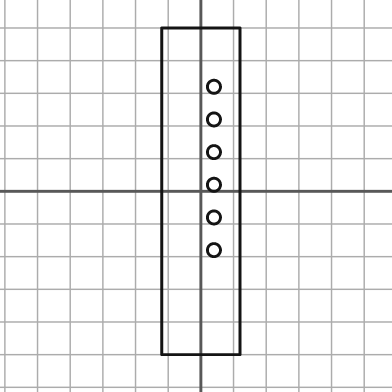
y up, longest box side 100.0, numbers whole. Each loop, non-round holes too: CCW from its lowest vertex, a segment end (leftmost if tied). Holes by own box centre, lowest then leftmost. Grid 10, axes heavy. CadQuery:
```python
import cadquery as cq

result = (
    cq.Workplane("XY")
    .moveTo(-12.0, -50.0)
    .lineTo(12.0, -50.0)
    .lineTo(12.0, 50.0)
    .lineTo(-12.0, 50.0)
    .close()
    .moveTo(4.0, -18.0)
    .circle(2.0)
    .moveTo(4.0, -8.0)
    .circle(2.0)
    .moveTo(4.0, 2.0)
    .circle(2.0)
    .moveTo(4.0, 12.0)
    .circle(2.0)
    .moveTo(4.0, 22.0)
    .circle(2.0)
    .moveTo(4.0, 32.0)
    .circle(2.0)
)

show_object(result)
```